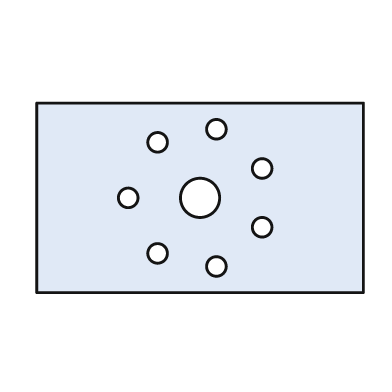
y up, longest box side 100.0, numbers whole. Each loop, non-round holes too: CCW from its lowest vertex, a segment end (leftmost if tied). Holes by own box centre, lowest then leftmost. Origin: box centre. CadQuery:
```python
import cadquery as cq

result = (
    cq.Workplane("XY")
    .moveTo(-50.0, -29.0)
    .lineTo(50.0, -29.0)
    .lineTo(50.0, 29.0)
    .lineTo(-50.0, 29.0)
    .close()
    .moveTo(5.0, -21.0)
    .circle(3.0)
    .moveTo(-13.0, -17.0)
    .circle(3.0)
    .moveTo(19.0, -9.0)
    .circle(3.0)
    .moveTo(-22.0, 0.0)
    .circle(3.0)
    .moveTo(0.0, 0.0)
    .circle(6.0)
    .moveTo(19.0, 9.0)
    .circle(3.0)
    .moveTo(-13.0, 17.0)
    .circle(3.0)
    .moveTo(5.0, 21.0)
    .circle(3.0)
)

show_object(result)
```